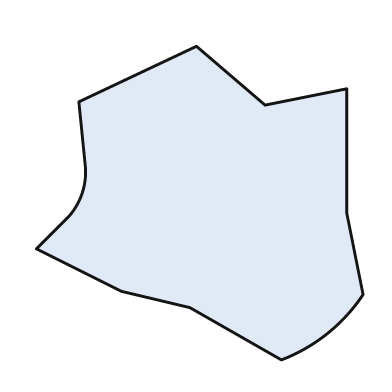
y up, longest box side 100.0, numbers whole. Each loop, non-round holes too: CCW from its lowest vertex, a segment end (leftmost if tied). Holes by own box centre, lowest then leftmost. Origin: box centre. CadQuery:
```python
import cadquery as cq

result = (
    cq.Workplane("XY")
    .moveTo(25.0, -48.0)
    .threePointArc((39.0, -40.0), (50.0, -28.0))
    .lineTo(45.0, -3.0)
    .lineTo(45.0, 35.0)
    .lineTo(20.0, 30.0)
    .lineTo(-1.0, 48.0)
    .lineTo(-37.0, 31.0)
    .lineTo(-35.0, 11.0)
    .threePointArc((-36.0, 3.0), (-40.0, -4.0))
    .lineTo(-50.0, -14.0)
    .lineTo(-24.0, -27.0)
    .lineTo(-3.0, -32.0)
    .close()
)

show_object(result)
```